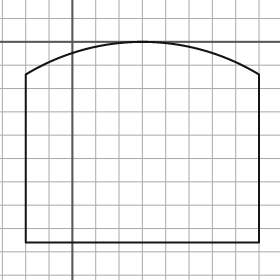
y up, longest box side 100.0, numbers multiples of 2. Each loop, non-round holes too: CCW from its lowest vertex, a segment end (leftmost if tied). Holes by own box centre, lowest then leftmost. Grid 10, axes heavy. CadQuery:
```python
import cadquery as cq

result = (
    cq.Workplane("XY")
    .moveTo(-20.0, -86.0)
    .lineTo(80.0, -86.0)
    .lineTo(80.0, -14.0)
    .threePointArc((30.0, 0.0), (-20.0, -14.0))
    .close()
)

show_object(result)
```